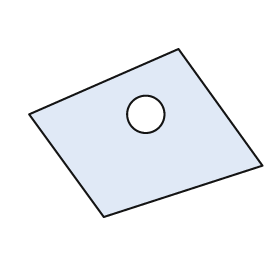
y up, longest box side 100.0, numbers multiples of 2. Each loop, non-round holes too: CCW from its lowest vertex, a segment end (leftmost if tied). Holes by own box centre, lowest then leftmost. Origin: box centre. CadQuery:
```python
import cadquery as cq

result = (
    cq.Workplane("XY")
    .moveTo(-18.0, -36.0)
    .lineTo(50.0, -14.0)
    .lineTo(14.0, 36.0)
    .lineTo(-50.0, 8.0)
    .close()
    .moveTo(0.0, 8.0)
    .circle(8.0)
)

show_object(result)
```